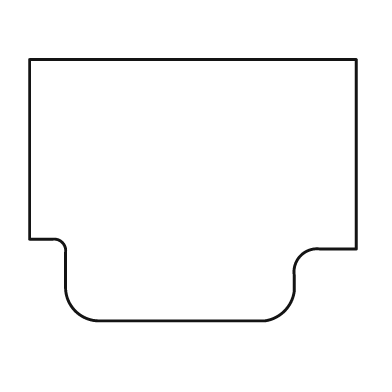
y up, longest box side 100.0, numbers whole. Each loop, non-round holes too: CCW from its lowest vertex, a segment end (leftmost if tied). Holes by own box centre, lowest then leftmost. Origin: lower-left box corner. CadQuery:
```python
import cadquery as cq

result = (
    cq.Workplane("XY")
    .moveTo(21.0, 0.0)
    .lineTo(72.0, 0.0)
    .threePointArc((78.0, 3.0), (81.0, 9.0))
    .lineTo(81.0, 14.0)
    .threePointArc((83.0, 20.0), (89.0, 22.0))
    .lineTo(100.0, 22.0)
    .lineTo(100.0, 80.0)
    .lineTo(0.0, 80.0)
    .lineTo(0.0, 25.0)
    .lineTo(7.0, 25.0)
    .threePointArc((10.0, 24.0), (11.0, 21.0))
    .lineTo(11.0, 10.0)
    .threePointArc((14.0, 3.0), (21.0, 0.0))
    .close()
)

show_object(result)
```